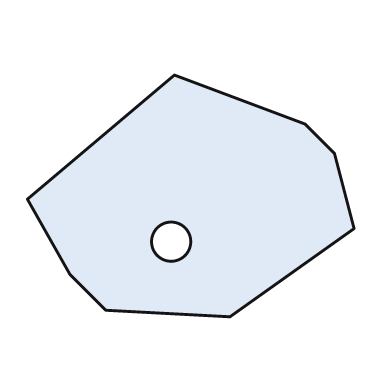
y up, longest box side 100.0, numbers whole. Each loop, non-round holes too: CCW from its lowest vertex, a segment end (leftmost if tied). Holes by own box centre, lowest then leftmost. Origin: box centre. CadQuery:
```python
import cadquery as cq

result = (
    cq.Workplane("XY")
    .moveTo(12.0, -37.0)
    .lineTo(50.0, -10.0)
    .lineTo(44.0, 13.0)
    .lineTo(35.0, 22.0)
    .lineTo(-5.0, 37.0)
    .lineTo(-50.0, -1.0)
    .lineTo(-37.0, -24.0)
    .lineTo(-26.0, -35.0)
    .close()
    .moveTo(-6.0, -14.0)
    .circle(6.0)
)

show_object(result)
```